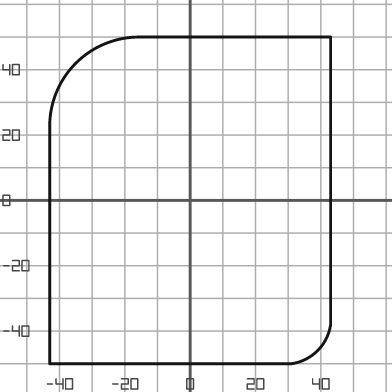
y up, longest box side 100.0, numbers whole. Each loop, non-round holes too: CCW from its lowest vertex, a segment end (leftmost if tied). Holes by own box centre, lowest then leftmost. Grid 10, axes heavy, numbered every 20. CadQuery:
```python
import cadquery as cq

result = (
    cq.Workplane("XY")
    .moveTo(-43.0, -50.0)
    .lineTo(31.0, -50.0)
    .threePointArc((39.0, -46.0), (43.0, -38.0))
    .lineTo(43.0, 50.0)
    .lineTo(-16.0, 50.0)
    .threePointArc((-35.0, 42.0), (-43.0, 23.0))
    .close()
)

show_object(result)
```